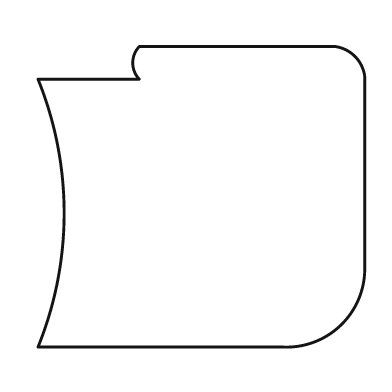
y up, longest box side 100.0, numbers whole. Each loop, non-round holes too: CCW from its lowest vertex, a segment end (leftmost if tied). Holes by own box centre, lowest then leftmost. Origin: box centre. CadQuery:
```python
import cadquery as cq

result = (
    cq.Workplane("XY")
    .moveTo(-50.0, -46.0)
    .lineTo(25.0, -46.0)
    .threePointArc((43.0, -39.0), (50.0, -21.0))
    .lineTo(50.0, 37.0)
    .threePointArc((47.0, 43.0), (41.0, 46.0))
    .lineTo(-19.0, 46.0)
    .threePointArc((-21.0, 41.0), (-19.0, 36.0))
    .lineTo(-50.0, 36.0)
    .threePointArc((-42.0, -5.0), (-50.0, -46.0))
    .close()
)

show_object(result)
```